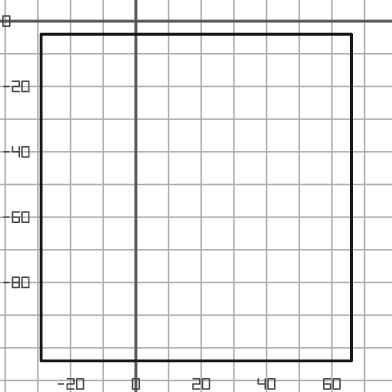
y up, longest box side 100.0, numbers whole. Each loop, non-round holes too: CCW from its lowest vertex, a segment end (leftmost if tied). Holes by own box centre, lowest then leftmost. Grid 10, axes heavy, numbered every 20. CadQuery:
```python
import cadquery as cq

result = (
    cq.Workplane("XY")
    .moveTo(-29.0, -104.0)
    .lineTo(66.0, -104.0)
    .lineTo(66.0, -4.0)
    .lineTo(-29.0, -4.0)
    .close()
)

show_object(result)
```